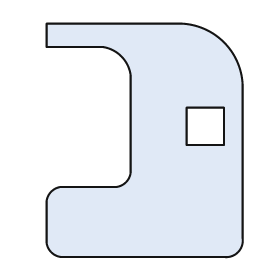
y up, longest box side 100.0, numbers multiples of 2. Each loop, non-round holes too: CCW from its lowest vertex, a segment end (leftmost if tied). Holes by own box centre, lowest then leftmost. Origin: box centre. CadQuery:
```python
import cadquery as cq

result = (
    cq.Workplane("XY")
    .moveTo(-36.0, -50.0)
    .lineTo(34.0, -50.0)
    .threePointArc((40.0, -48.0), (42.0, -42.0))
    .lineTo(42.0, 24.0)
    .threePointArc((34.0, 42.0), (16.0, 50.0))
    .lineTo(-42.0, 50.0)
    .lineTo(-42.0, 40.0)
    .lineTo(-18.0, 40.0)
    .threePointArc((-10.0, 36.0), (-6.0, 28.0))
    .lineTo(-6.0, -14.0)
    .threePointArc((-8.0, -18.0), (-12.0, -20.0))
    .lineTo(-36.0, -20.0)
    .threePointArc((-40.0, -22.0), (-42.0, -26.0))
    .lineTo(-42.0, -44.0)
    .threePointArc((-40.0, -48.0), (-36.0, -50.0))
    .close()
    .moveTo(18.0, -2.0)
    .lineTo(34.0, -2.0)
    .lineTo(34.0, 14.0)
    .lineTo(18.0, 14.0)
    .close()
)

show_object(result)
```